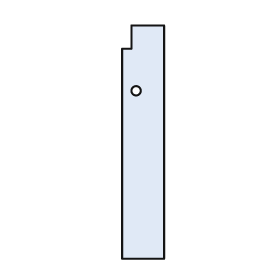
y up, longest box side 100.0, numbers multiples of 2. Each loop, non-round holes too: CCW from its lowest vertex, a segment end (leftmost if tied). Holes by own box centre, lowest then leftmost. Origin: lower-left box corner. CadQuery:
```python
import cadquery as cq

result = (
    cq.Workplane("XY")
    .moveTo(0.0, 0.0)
    .lineTo(18.0, 0.0)
    .lineTo(18.0, 100.0)
    .lineTo(4.0, 100.0)
    .lineTo(4.0, 90.0)
    .lineTo(0.0, 90.0)
    .close()
    .moveTo(6.0, 72.0)
    .circle(2.0)
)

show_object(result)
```